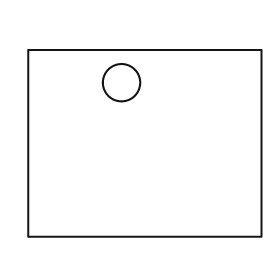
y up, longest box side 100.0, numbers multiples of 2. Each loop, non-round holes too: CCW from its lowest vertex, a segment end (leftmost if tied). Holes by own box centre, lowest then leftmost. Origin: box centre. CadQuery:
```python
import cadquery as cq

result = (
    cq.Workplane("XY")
    .moveTo(-50.0, -40.0)
    .lineTo(50.0, -40.0)
    .lineTo(50.0, 40.0)
    .lineTo(-50.0, 40.0)
    .close()
    .moveTo(-10.0, 26.0)
    .circle(8.0)
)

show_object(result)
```